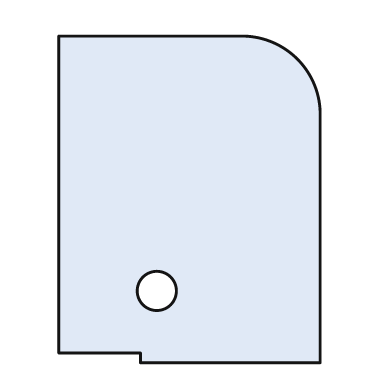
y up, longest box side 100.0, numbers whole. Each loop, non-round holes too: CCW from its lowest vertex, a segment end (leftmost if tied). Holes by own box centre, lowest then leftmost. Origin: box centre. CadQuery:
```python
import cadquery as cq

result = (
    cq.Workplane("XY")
    .moveTo(-15.0, -50.0)
    .lineTo(40.0, -50.0)
    .lineTo(40.0, 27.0)
    .threePointArc((33.0, 43.0), (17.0, 50.0))
    .lineTo(-40.0, 50.0)
    .lineTo(-40.0, -47.0)
    .lineTo(-15.0, -47.0)
    .close()
    .moveTo(-10.0, -28.0)
    .circle(6.0)
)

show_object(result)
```